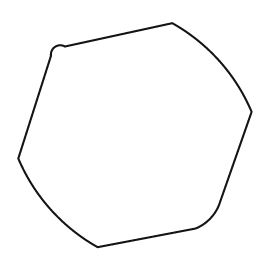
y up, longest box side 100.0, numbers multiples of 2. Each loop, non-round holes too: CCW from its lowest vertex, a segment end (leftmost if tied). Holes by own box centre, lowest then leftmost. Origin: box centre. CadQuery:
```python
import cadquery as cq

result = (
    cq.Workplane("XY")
    .moveTo(-16.0, -48.0)
    .lineTo(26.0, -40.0)
    .threePointArc((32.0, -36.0), (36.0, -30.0))
    .lineTo(50.0, 10.0)
    .threePointArc((36.0, 32.0), (16.0, 48.0))
    .lineTo(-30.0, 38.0)
    .threePointArc((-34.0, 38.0), (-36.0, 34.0))
    .lineTo(-50.0, -10.0)
    .threePointArc((-36.0, -32.0), (-16.0, -48.0))
    .close()
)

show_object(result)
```